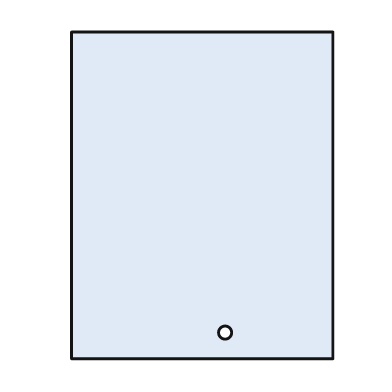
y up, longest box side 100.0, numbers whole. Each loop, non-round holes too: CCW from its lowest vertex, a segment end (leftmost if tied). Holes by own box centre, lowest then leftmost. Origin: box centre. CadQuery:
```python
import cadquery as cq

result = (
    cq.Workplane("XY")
    .moveTo(-40.0, -50.0)
    .lineTo(40.0, -50.0)
    .lineTo(40.0, 50.0)
    .lineTo(-40.0, 50.0)
    .close()
    .moveTo(7.0, -42.0)
    .circle(2.0)
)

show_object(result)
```